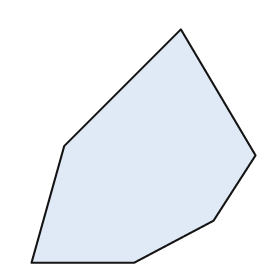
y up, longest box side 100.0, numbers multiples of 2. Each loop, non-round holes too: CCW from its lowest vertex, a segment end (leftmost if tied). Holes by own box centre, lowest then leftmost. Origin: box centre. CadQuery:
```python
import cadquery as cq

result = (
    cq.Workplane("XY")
    .moveTo(-48.0, -50.0)
    .lineTo(-4.0, -50.0)
    .lineTo(30.0, -32.0)
    .lineTo(48.0, -4.0)
    .lineTo(16.0, 50.0)
    .lineTo(-34.0, 0.0)
    .close()
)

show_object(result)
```